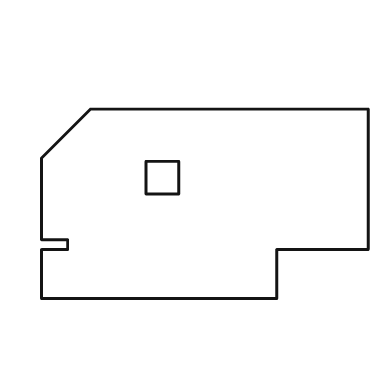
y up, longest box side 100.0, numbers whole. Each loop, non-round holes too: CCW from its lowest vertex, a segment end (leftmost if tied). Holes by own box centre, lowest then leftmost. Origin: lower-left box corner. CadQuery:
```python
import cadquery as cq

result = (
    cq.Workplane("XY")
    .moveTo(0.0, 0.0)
    .lineTo(72.0, 0.0)
    .lineTo(72.0, 15.0)
    .lineTo(100.0, 15.0)
    .lineTo(100.0, 58.0)
    .lineTo(15.0, 58.0)
    .lineTo(0.0, 43.0)
    .lineTo(0.0, 18.0)
    .lineTo(8.0, 18.0)
    .lineTo(8.0, 15.0)
    .lineTo(0.0, 15.0)
    .close()
    .moveTo(32.0, 32.0)
    .lineTo(42.0, 32.0)
    .lineTo(42.0, 42.0)
    .lineTo(32.0, 42.0)
    .close()
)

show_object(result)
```